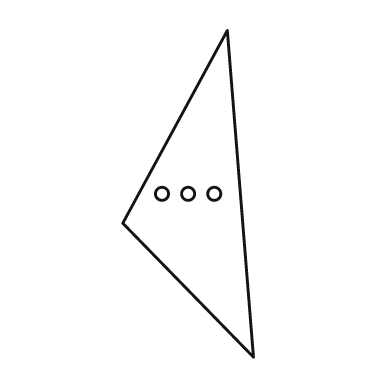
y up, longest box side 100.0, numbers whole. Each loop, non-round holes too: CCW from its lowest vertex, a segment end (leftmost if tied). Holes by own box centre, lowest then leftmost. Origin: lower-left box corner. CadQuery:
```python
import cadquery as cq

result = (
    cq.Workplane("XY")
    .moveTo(40.0, 0.0)
    .lineTo(32.0, 100.0)
    .lineTo(0.0, 41.0)
    .close()
    .moveTo(12.0, 50.0)
    .circle(2.0)
    .moveTo(20.0, 50.0)
    .circle(2.0)
    .moveTo(28.0, 50.0)
    .circle(2.0)
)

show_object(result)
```